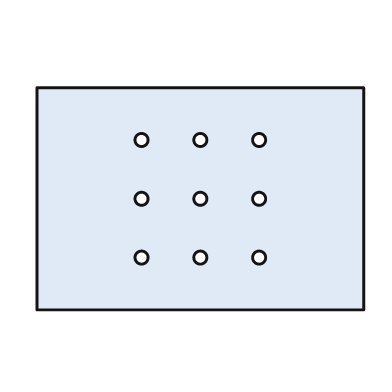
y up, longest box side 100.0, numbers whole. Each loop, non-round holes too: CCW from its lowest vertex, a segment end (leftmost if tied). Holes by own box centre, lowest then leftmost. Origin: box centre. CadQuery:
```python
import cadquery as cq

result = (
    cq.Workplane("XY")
    .moveTo(-50.0, -34.0)
    .lineTo(50.0, -34.0)
    .lineTo(50.0, 34.0)
    .lineTo(-50.0, 34.0)
    .close()
    .moveTo(-18.0, -18.0)
    .circle(2.0)
    .moveTo(0.0, -18.0)
    .circle(2.0)
    .moveTo(18.0, -18.0)
    .circle(2.0)
    .moveTo(-18.0, 0.0)
    .circle(2.0)
    .moveTo(0.0, 0.0)
    .circle(2.0)
    .moveTo(18.0, 0.0)
    .circle(2.0)
    .moveTo(-18.0, 18.0)
    .circle(2.0)
    .moveTo(0.0, 18.0)
    .circle(2.0)
    .moveTo(18.0, 18.0)
    .circle(2.0)
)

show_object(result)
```